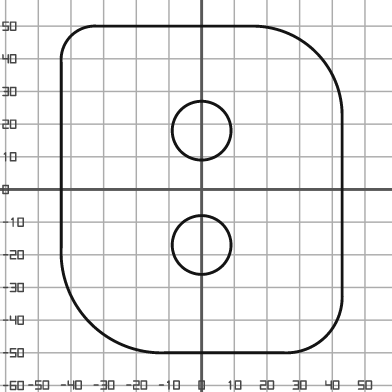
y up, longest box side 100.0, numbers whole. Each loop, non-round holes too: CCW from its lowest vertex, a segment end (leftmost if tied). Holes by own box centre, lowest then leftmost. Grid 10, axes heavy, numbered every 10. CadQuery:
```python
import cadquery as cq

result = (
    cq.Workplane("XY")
    .moveTo(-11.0, -50.0)
    .lineTo(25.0, -50.0)
    .threePointArc((38.0, -45.0), (43.0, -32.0))
    .lineTo(43.0, 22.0)
    .threePointArc((35.0, 42.0), (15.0, 50.0))
    .lineTo(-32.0, 50.0)
    .threePointArc((-40.0, 47.0), (-43.0, 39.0))
    .lineTo(-43.0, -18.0)
    .threePointArc((-34.0, -41.0), (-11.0, -50.0))
    .close()
    .moveTo(0.0, -17.0)
    .circle(9.0)
    .moveTo(0.0, 18.0)
    .circle(9.0)
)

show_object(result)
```